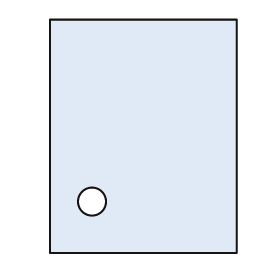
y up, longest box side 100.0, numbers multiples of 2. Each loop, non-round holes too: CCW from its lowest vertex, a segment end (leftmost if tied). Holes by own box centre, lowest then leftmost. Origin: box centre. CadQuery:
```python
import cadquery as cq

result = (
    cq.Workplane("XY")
    .moveTo(-40.0, -50.0)
    .lineTo(40.0, -50.0)
    .lineTo(40.0, 50.0)
    .lineTo(-40.0, 50.0)
    .close()
    .moveTo(-22.0, -28.0)
    .circle(6.0)
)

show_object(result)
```